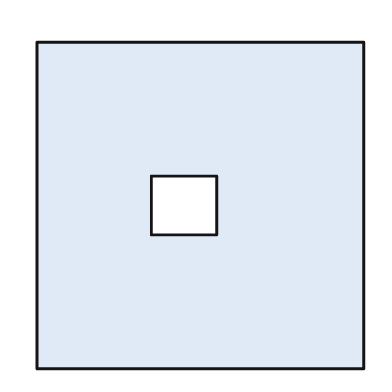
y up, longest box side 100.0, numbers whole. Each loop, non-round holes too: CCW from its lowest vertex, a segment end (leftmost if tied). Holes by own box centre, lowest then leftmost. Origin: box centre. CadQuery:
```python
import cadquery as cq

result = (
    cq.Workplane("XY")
    .moveTo(-50.0, -50.0)
    .lineTo(50.0, -50.0)
    .lineTo(50.0, 50.0)
    .lineTo(-50.0, 50.0)
    .close()
    .moveTo(-15.0, -9.0)
    .lineTo(5.0, -9.0)
    .lineTo(5.0, 9.0)
    .lineTo(-15.0, 9.0)
    .close()
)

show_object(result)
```